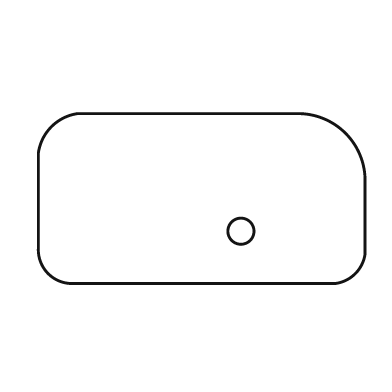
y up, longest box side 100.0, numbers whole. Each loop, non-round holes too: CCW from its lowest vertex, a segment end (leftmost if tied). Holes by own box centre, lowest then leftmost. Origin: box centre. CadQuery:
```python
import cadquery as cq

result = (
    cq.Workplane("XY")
    .moveTo(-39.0, -26.0)
    .lineTo(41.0, -26.0)
    .threePointArc((47.0, -23.0), (50.0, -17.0))
    .lineTo(50.0, 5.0)
    .threePointArc((44.0, 20.0), (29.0, 26.0))
    .lineTo(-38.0, 26.0)
    .threePointArc((-46.0, 22.0), (-50.0, 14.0))
    .lineTo(-50.0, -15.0)
    .threePointArc((-47.0, -23.0), (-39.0, -26.0))
    .close()
    .moveTo(12.0, -10.0)
    .circle(4.0)
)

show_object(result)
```